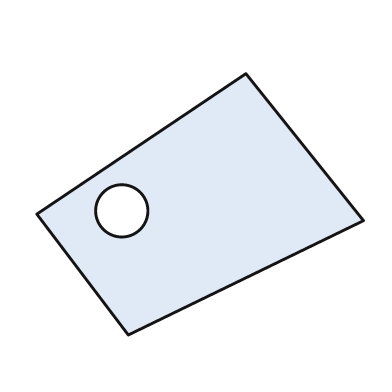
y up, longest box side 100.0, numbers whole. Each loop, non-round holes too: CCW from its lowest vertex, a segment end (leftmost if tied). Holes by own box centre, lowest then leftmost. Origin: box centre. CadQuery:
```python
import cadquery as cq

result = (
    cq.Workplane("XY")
    .moveTo(-22.0, -40.0)
    .lineTo(50.0, -5.0)
    .lineTo(14.0, 40.0)
    .lineTo(-50.0, -3.0)
    .close()
    .moveTo(-24.0, -2.0)
    .circle(8.0)
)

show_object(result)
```